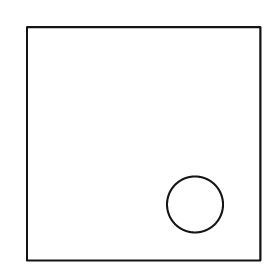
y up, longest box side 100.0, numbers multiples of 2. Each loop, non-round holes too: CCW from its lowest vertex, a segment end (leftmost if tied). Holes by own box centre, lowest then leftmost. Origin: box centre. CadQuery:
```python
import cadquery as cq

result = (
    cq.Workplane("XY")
    .moveTo(-50.0, -50.0)
    .lineTo(50.0, -50.0)
    .lineTo(50.0, 50.0)
    .lineTo(-50.0, 50.0)
    .close()
    .moveTo(22.0, -26.0)
    .circle(12.0)
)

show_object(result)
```